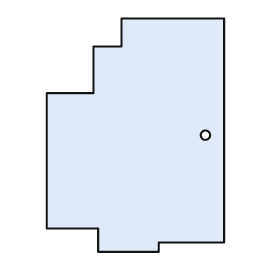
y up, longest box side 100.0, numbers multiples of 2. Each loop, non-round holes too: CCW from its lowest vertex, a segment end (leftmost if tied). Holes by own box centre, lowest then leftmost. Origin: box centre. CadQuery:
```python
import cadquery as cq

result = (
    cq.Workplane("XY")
    .moveTo(-16.0, -50.0)
    .lineTo(10.0, -50.0)
    .lineTo(10.0, -46.0)
    .lineTo(38.0, -46.0)
    .lineTo(38.0, 50.0)
    .lineTo(-6.0, 50.0)
    .lineTo(-6.0, 38.0)
    .lineTo(-18.0, 38.0)
    .lineTo(-18.0, 18.0)
    .lineTo(-38.0, 18.0)
    .lineTo(-38.0, -40.0)
    .lineTo(-16.0, -40.0)
    .close()
    .moveTo(30.0, 0.0)
    .circle(2.0)
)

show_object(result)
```